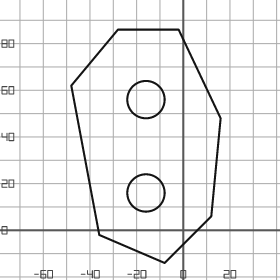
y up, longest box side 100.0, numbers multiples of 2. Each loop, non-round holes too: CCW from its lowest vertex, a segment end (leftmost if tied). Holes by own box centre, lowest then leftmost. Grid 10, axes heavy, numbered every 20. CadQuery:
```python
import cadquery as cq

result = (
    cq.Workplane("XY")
    .moveTo(-8.0, -14.0)
    .lineTo(12.0, 6.0)
    .lineTo(16.0, 48.0)
    .lineTo(-2.0, 86.0)
    .lineTo(-28.0, 86.0)
    .lineTo(-48.0, 62.0)
    .lineTo(-36.0, -2.0)
    .close()
    .moveTo(-16.0, 16.0)
    .circle(8.0)
    .moveTo(-16.0, 56.0)
    .circle(8.0)
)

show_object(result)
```